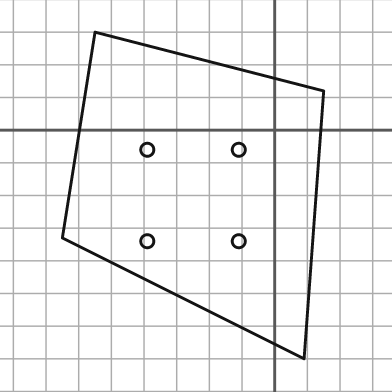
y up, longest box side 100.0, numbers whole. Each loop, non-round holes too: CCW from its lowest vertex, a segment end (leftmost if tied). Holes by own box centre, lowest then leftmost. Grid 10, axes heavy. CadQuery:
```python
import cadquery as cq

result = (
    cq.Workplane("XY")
    .moveTo(9.0, -70.0)
    .lineTo(15.0, 12.0)
    .lineTo(-55.0, 30.0)
    .lineTo(-65.0, -33.0)
    .close()
    .moveTo(-39.0, -34.0)
    .circle(2.0)
    .moveTo(-11.0, -34.0)
    .circle(2.0)
    .moveTo(-39.0, -6.0)
    .circle(2.0)
    .moveTo(-11.0, -6.0)
    .circle(2.0)
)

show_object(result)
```